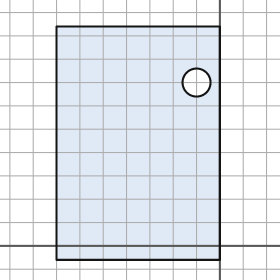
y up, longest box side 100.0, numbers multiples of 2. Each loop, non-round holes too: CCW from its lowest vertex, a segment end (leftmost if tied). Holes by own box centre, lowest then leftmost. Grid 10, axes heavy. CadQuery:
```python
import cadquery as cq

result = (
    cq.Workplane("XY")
    .moveTo(-70.0, -6.0)
    .lineTo(0.0, -6.0)
    .lineTo(0.0, 94.0)
    .lineTo(-70.0, 94.0)
    .close()
    .moveTo(-10.0, 70.0)
    .circle(6.0)
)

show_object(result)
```